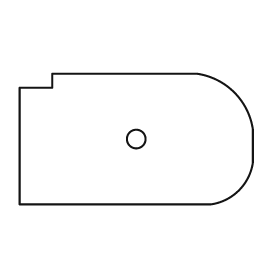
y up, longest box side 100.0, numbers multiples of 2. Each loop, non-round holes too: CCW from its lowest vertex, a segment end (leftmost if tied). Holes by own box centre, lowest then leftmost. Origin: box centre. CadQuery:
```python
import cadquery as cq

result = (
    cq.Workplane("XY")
    .moveTo(-50.0, -28.0)
    .lineTo(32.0, -28.0)
    .threePointArc((44.0, -22.0), (50.0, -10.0))
    .lineTo(50.0, 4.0)
    .threePointArc((42.0, 20.0), (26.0, 28.0))
    .lineTo(-36.0, 28.0)
    .lineTo(-36.0, 22.0)
    .lineTo(-50.0, 22.0)
    .close()
    .moveTo(0.0, 0.0)
    .circle(4.0)
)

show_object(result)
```